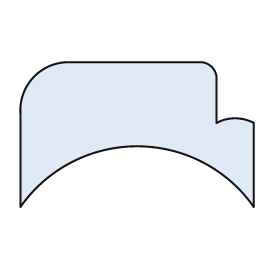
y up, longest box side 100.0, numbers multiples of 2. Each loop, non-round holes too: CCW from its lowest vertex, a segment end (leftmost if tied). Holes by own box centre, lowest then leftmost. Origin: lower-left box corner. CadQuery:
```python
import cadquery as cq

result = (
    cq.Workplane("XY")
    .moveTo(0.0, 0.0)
    .threePointArc((50.0, 26.0), (100.0, 0.0))
    .lineTo(100.0, 36.0)
    .threePointArc((92.0, 38.0), (84.0, 36.0))
    .lineTo(84.0, 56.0)
    .threePointArc((82.0, 60.0), (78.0, 62.0))
    .lineTo(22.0, 62.0)
    .threePointArc((6.0, 56.0), (0.0, 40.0))
    .close()
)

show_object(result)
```